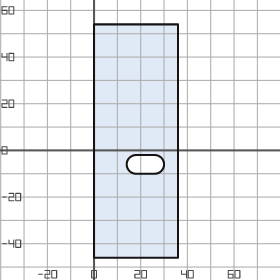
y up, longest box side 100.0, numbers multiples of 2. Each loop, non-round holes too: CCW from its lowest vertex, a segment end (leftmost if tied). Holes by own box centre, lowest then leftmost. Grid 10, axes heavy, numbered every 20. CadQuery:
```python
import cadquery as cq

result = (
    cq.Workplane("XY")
    .moveTo(0.0, -46.0)
    .lineTo(36.0, -46.0)
    .lineTo(36.0, 54.0)
    .lineTo(0.0, 54.0)
    .close()
    .moveTo(18.0, -10.0)
    .lineTo(26.0, -10.0)
    .threePointArc((30.0, -6.0), (26.0, -2.0))
    .lineTo(18.0, -2.0)
    .threePointArc((14.0, -6.0), (18.0, -10.0))
    .close()
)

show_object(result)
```